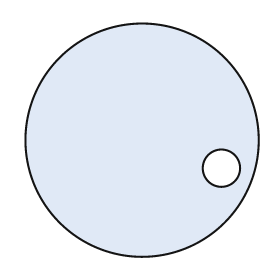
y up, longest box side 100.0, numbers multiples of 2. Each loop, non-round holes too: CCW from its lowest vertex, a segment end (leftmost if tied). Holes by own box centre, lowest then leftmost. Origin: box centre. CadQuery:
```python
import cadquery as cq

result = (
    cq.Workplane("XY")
    .moveTo(0.0, 0.0)
    .circle(50.0)
    .moveTo(34.0, -12.0)
    .circle(8.0)
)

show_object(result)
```